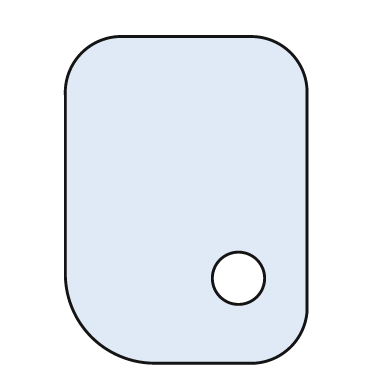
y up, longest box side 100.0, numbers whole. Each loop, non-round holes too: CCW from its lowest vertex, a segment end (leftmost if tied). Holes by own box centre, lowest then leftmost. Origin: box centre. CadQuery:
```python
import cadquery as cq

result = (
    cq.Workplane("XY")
    .moveTo(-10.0, -50.0)
    .lineTo(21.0, -50.0)
    .threePointArc((32.0, -45.0), (37.0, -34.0))
    .lineTo(37.0, 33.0)
    .threePointArc((32.0, 45.0), (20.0, 50.0))
    .lineTo(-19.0, 50.0)
    .threePointArc((-32.0, 45.0), (-37.0, 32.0))
    .lineTo(-37.0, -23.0)
    .threePointArc((-29.0, -42.0), (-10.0, -50.0))
    .close()
    .moveTo(16.0, -24.0)
    .circle(8.0)
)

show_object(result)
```